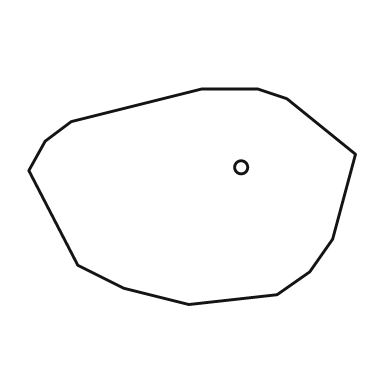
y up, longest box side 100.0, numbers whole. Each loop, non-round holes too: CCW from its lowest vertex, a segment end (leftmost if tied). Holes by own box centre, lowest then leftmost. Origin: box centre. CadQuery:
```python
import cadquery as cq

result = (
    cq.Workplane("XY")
    .moveTo(-1.0, -33.0)
    .lineTo(26.0, -30.0)
    .lineTo(36.0, -23.0)
    .lineTo(43.0, -13.0)
    .lineTo(50.0, 13.0)
    .lineTo(29.0, 30.0)
    .lineTo(20.0, 33.0)
    .lineTo(3.0, 33.0)
    .lineTo(-37.0, 23.0)
    .lineTo(-45.0, 17.0)
    .lineTo(-50.0, 8.0)
    .lineTo(-35.0, -21.0)
    .lineTo(-21.0, -28.0)
    .close()
    .moveTo(15.0, 9.0)
    .circle(2.0)
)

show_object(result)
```